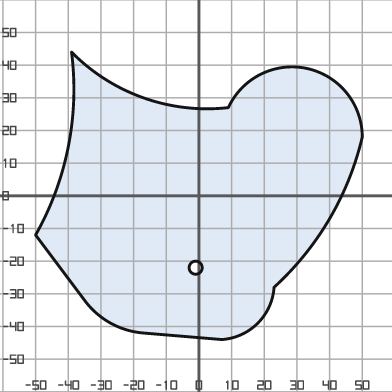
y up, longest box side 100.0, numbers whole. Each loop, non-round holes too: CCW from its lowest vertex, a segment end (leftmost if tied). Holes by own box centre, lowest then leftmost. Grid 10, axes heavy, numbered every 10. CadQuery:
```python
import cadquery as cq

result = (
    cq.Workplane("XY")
    .moveTo(7.0, -44.0)
    .threePointArc((18.0, -39.0), (23.0, -28.0))
    .threePointArc((40.0, -7.0), (50.0, 18.0))
    .threePointArc((33.0, 39.0), (9.0, 27.0))
    .threePointArc((-17.0, 30.0), (-39.0, 44.0))
    .threePointArc((-40.0, 15.0), (-50.0, -12.0))
    .lineTo(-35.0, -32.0)
    .threePointArc((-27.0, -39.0), (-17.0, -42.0))
    .close()
    .moveTo(-1.0, -22.0)
    .circle(2.0)
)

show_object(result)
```